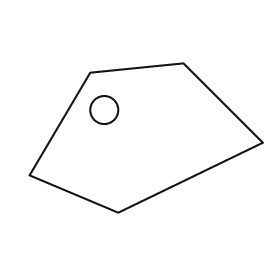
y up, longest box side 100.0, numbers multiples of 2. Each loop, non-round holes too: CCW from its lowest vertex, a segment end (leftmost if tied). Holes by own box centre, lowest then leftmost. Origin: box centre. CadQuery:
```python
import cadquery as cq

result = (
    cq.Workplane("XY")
    .moveTo(-12.0, -32.0)
    .lineTo(50.0, -2.0)
    .lineTo(16.0, 32.0)
    .lineTo(-24.0, 28.0)
    .lineTo(-50.0, -16.0)
    .close()
    .moveTo(-18.0, 12.0)
    .circle(6.0)
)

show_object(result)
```